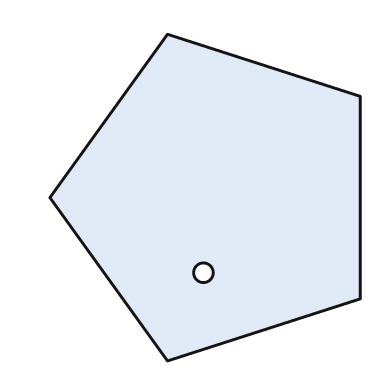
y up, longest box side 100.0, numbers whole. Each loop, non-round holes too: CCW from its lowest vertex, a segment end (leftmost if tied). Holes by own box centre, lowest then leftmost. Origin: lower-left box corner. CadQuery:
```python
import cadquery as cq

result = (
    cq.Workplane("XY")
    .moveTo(36.0, 0.0)
    .lineTo(95.0, 19.0)
    .lineTo(95.0, 81.0)
    .lineTo(36.0, 100.0)
    .lineTo(0.0, 50.0)
    .close()
    .moveTo(47.0, 27.0)
    .circle(3.0)
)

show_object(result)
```